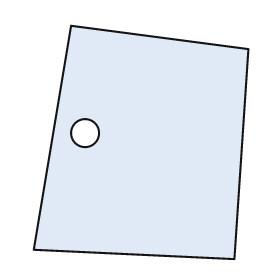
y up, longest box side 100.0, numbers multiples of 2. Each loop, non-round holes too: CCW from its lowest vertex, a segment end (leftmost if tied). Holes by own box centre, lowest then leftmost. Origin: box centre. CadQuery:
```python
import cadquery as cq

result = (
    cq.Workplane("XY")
    .moveTo(40.0, -50.0)
    .lineTo(46.0, 40.0)
    .lineTo(-30.0, 50.0)
    .lineTo(-46.0, -46.0)
    .close()
    .moveTo(-24.0, 4.0)
    .circle(6.0)
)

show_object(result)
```